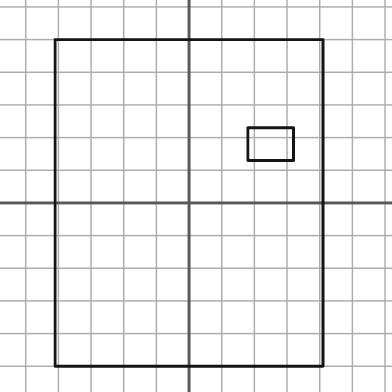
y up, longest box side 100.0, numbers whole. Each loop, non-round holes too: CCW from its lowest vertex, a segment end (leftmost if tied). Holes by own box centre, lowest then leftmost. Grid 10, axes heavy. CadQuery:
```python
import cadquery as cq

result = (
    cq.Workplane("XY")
    .moveTo(-41.0, -50.0)
    .lineTo(41.0, -50.0)
    .lineTo(41.0, 50.0)
    .lineTo(-41.0, 50.0)
    .close()
    .moveTo(18.0, 13.0)
    .lineTo(32.0, 13.0)
    .lineTo(32.0, 23.0)
    .lineTo(18.0, 23.0)
    .close()
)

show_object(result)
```